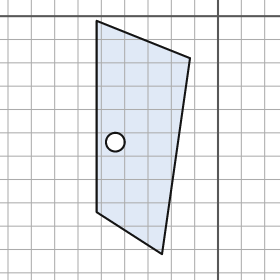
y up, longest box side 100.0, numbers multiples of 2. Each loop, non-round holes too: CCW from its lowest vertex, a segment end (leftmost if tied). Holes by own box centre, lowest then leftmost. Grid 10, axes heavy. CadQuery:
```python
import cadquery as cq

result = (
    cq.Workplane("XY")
    .moveTo(-24.0, -102.0)
    .lineTo(-12.0, -18.0)
    .lineTo(-52.0, -2.0)
    .lineTo(-52.0, -84.0)
    .close()
    .moveTo(-44.0, -54.0)
    .circle(4.0)
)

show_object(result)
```